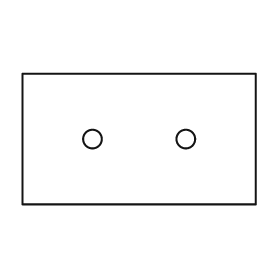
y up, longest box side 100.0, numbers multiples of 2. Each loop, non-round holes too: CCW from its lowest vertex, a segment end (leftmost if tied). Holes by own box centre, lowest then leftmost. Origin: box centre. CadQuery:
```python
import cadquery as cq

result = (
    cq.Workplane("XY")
    .moveTo(-50.0, -28.0)
    .lineTo(50.0, -28.0)
    .lineTo(50.0, 28.0)
    .lineTo(-50.0, 28.0)
    .close()
    .moveTo(-20.0, 0.0)
    .circle(4.0)
    .moveTo(20.0, 0.0)
    .circle(4.0)
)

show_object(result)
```